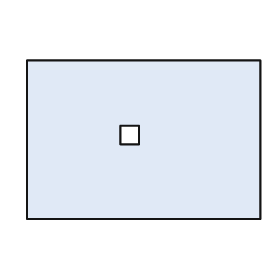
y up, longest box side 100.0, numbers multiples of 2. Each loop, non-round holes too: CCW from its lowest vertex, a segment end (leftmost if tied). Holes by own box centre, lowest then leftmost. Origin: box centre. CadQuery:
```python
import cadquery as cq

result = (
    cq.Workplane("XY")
    .moveTo(-50.0, -34.0)
    .lineTo(50.0, -34.0)
    .lineTo(50.0, 34.0)
    .lineTo(-50.0, 34.0)
    .close()
    .moveTo(-10.0, -2.0)
    .lineTo(-2.0, -2.0)
    .lineTo(-2.0, 6.0)
    .lineTo(-10.0, 6.0)
    .close()
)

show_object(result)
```